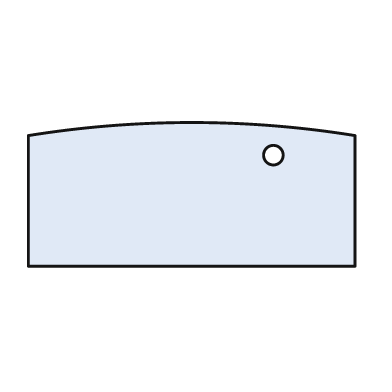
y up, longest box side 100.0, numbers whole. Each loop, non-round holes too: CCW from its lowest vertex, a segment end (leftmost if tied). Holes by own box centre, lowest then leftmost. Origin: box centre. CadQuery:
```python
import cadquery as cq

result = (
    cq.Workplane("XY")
    .moveTo(-50.0, -22.0)
    .lineTo(50.0, -22.0)
    .lineTo(50.0, 18.0)
    .threePointArc((0.0, 22.0), (-50.0, 18.0))
    .close()
    .moveTo(25.0, 12.0)
    .circle(3.0)
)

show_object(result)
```